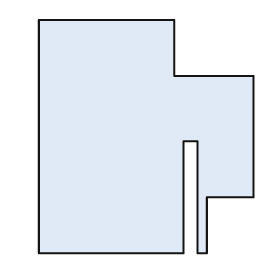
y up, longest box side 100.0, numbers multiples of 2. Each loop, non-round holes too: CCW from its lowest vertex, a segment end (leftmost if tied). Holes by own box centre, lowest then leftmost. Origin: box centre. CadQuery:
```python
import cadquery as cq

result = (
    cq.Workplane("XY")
    .moveTo(-46.0, -50.0)
    .lineTo(16.0, -50.0)
    .lineTo(16.0, -2.0)
    .lineTo(22.0, -2.0)
    .lineTo(22.0, -50.0)
    .lineTo(26.0, -50.0)
    .lineTo(26.0, -26.0)
    .lineTo(46.0, -26.0)
    .lineTo(46.0, 26.0)
    .lineTo(12.0, 26.0)
    .lineTo(12.0, 50.0)
    .lineTo(-46.0, 50.0)
    .close()
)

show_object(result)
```